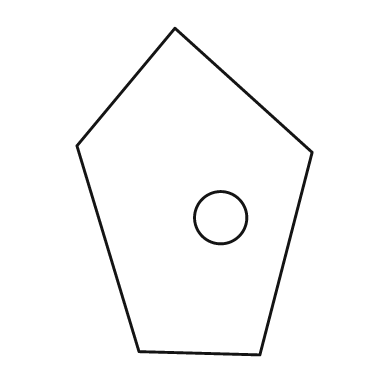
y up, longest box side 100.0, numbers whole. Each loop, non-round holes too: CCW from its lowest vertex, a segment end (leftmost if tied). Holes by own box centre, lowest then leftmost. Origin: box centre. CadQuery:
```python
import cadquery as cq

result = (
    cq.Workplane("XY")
    .moveTo(20.0, -50.0)
    .lineTo(36.0, 12.0)
    .lineTo(-6.0, 50.0)
    .lineTo(-36.0, 14.0)
    .lineTo(-17.0, -49.0)
    .close()
    .moveTo(8.0, -8.0)
    .circle(8.0)
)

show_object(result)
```